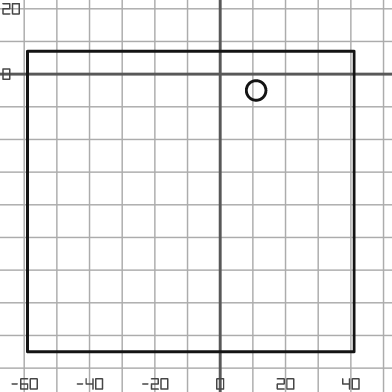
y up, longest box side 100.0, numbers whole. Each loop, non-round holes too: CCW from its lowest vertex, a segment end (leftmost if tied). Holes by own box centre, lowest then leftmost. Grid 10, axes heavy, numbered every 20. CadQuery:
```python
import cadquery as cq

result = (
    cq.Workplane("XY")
    .moveTo(-59.0, -85.0)
    .lineTo(41.0, -85.0)
    .lineTo(41.0, 7.0)
    .lineTo(-59.0, 7.0)
    .close()
    .moveTo(11.0, -5.0)
    .circle(3.0)
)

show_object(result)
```